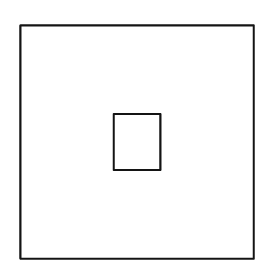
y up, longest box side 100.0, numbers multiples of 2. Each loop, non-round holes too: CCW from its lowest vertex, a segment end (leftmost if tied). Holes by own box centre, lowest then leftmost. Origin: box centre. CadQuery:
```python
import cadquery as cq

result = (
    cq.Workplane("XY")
    .moveTo(-50.0, -50.0)
    .lineTo(50.0, -50.0)
    .lineTo(50.0, 50.0)
    .lineTo(-50.0, 50.0)
    .close()
    .moveTo(-10.0, -12.0)
    .lineTo(10.0, -12.0)
    .lineTo(10.0, 12.0)
    .lineTo(-10.0, 12.0)
    .close()
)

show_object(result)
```